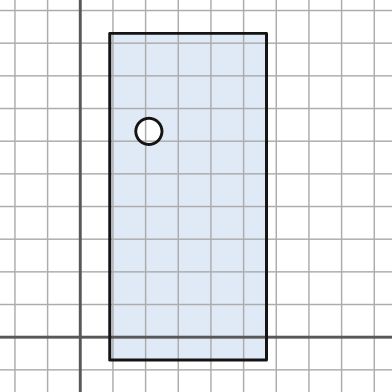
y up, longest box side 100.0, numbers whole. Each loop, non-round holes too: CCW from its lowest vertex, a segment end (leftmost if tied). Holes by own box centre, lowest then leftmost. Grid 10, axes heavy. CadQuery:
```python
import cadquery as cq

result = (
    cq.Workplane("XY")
    .moveTo(9.0, -7.0)
    .lineTo(57.0, -7.0)
    .lineTo(57.0, 93.0)
    .lineTo(9.0, 93.0)
    .close()
    .moveTo(21.0, 63.0)
    .circle(4.0)
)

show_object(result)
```